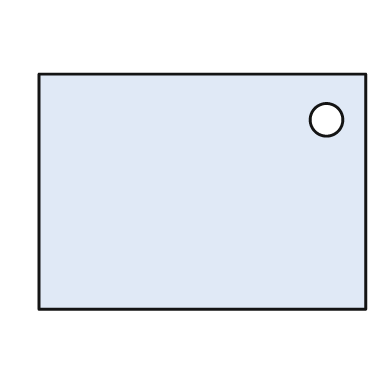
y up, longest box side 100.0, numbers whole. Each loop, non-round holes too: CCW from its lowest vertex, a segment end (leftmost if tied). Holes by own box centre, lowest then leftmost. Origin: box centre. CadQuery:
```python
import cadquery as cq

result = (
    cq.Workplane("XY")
    .moveTo(-50.0, -36.0)
    .lineTo(50.0, -36.0)
    .lineTo(50.0, 36.0)
    .lineTo(-50.0, 36.0)
    .close()
    .moveTo(38.0, 22.0)
    .circle(5.0)
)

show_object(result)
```